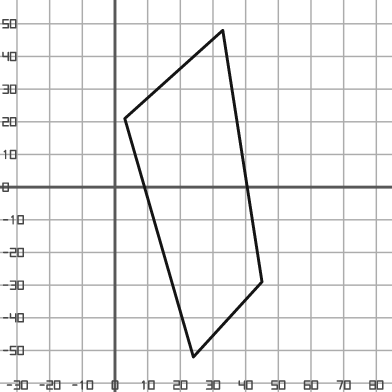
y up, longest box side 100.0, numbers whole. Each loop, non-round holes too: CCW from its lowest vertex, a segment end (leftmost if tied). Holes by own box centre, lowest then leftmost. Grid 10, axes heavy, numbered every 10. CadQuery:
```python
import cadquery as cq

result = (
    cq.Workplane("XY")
    .moveTo(24.0, -52.0)
    .lineTo(45.0, -29.0)
    .lineTo(33.0, 48.0)
    .lineTo(3.0, 21.0)
    .close()
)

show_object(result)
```